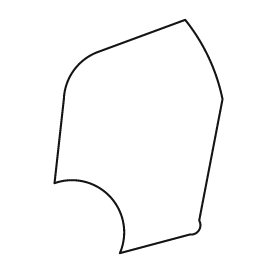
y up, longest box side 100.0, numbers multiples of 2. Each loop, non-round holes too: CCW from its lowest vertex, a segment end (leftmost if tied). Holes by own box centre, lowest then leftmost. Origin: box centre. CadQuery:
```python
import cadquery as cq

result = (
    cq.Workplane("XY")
    .moveTo(-8.0, -50.0)
    .lineTo(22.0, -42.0)
    .threePointArc((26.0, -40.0), (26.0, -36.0))
    .lineTo(36.0, 16.0)
    .threePointArc((30.0, 34.0), (20.0, 50.0))
    .lineTo(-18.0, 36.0)
    .threePointArc((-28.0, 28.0), (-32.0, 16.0))
    .lineTo(-36.0, -20.0)
    .threePointArc((-12.0, -26.0), (-8.0, -50.0))
    .close()
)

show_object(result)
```